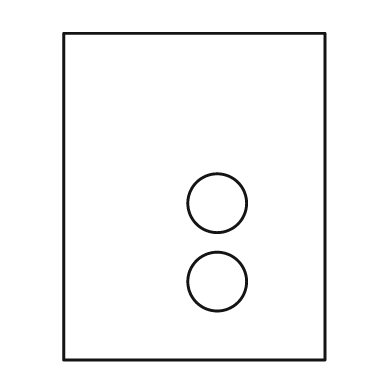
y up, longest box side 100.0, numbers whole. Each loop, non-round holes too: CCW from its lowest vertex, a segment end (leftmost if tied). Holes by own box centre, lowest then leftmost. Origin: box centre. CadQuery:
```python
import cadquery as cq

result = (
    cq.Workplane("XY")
    .moveTo(-40.0, -50.0)
    .lineTo(40.0, -50.0)
    .lineTo(40.0, 50.0)
    .lineTo(-40.0, 50.0)
    .close()
    .moveTo(7.0, -26.0)
    .circle(9.0)
    .moveTo(7.0, -2.0)
    .circle(9.0)
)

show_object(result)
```